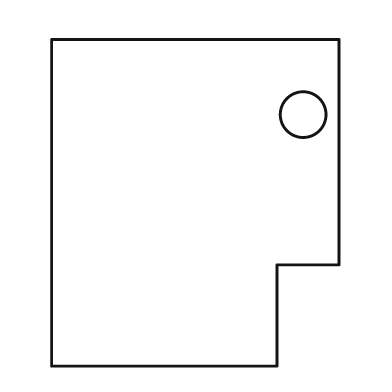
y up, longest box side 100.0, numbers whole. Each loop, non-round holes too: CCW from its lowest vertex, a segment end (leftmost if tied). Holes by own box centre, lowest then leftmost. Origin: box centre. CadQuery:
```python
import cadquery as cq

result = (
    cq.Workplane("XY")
    .moveTo(-44.0, -50.0)
    .lineTo(25.0, -50.0)
    .lineTo(25.0, -19.0)
    .lineTo(44.0, -19.0)
    .lineTo(44.0, 50.0)
    .lineTo(-44.0, 50.0)
    .close()
    .moveTo(33.0, 27.0)
    .circle(7.0)
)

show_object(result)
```